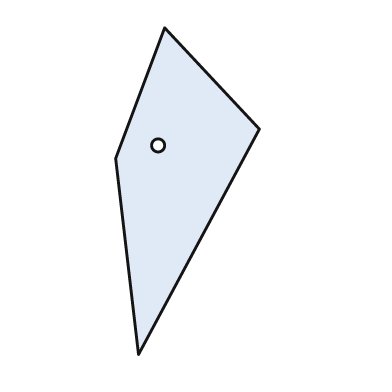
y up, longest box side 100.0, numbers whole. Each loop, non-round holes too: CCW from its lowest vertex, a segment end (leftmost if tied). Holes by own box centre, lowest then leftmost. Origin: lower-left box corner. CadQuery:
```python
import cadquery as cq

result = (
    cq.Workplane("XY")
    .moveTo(7.0, 0.0)
    .lineTo(44.0, 69.0)
    .lineTo(15.0, 100.0)
    .lineTo(0.0, 60.0)
    .close()
    .moveTo(13.0, 64.0)
    .circle(2.0)
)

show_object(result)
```